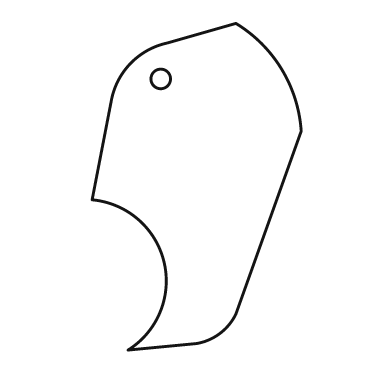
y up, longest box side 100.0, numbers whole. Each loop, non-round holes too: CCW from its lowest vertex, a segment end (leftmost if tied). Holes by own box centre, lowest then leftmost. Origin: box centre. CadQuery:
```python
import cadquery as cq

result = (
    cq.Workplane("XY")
    .moveTo(-21.0, -50.0)
    .lineTo(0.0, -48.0)
    .threePointArc((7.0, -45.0), (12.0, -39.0))
    .lineTo(32.0, 17.0)
    .threePointArc((26.0, 36.0), (12.0, 50.0))
    .lineTo(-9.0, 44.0)
    .threePointArc((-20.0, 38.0), (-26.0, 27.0))
    .lineTo(-32.0, -4.0)
    .threePointArc((-10.0, -23.0), (-21.0, -50.0))
    .close()
    .moveTo(-11.0, 33.0)
    .circle(3.0)
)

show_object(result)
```